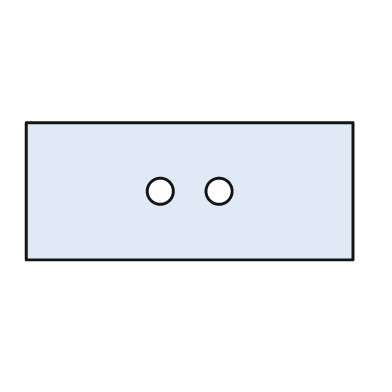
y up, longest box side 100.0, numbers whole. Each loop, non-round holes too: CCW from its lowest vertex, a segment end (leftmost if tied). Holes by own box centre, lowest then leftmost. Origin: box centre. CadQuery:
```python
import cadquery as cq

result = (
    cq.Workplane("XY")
    .moveTo(-50.0, -21.0)
    .lineTo(50.0, -21.0)
    .lineTo(50.0, 21.0)
    .lineTo(-50.0, 21.0)
    .close()
    .moveTo(-9.0, 0.0)
    .circle(4.0)
    .moveTo(9.0, 0.0)
    .circle(4.0)
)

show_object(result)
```